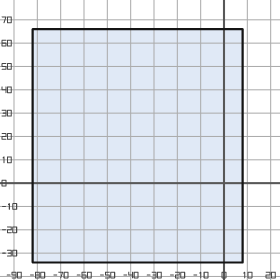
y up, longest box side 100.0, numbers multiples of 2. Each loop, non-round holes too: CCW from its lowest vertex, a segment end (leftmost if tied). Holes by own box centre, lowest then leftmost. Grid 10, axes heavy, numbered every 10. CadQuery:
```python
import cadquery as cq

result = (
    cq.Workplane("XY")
    .moveTo(-82.0, -34.0)
    .lineTo(8.0, -34.0)
    .lineTo(8.0, 66.0)
    .lineTo(-82.0, 66.0)
    .close()
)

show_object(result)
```